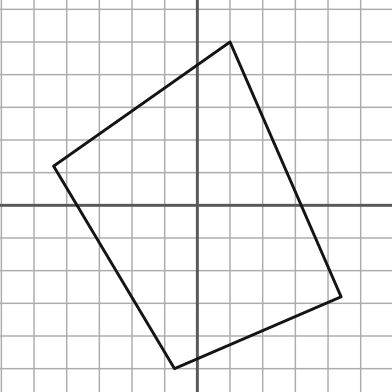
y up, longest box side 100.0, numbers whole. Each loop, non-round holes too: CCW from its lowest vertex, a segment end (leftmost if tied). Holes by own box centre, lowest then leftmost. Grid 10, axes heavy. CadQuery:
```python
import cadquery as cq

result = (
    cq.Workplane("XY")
    .moveTo(-7.0, -50.0)
    .lineTo(44.0, -28.0)
    .lineTo(10.0, 50.0)
    .lineTo(-44.0, 12.0)
    .close()
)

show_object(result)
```